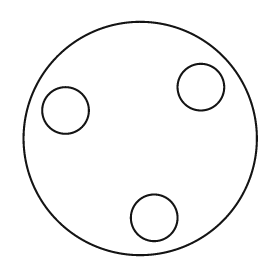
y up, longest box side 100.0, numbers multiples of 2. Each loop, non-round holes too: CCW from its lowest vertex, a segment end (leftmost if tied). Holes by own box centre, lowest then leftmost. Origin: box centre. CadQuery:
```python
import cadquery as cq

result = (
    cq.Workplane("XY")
    .moveTo(0.0, 0.0)
    .circle(50.0)
    .moveTo(6.0, -34.0)
    .circle(10.0)
    .moveTo(-32.0, 12.0)
    .circle(10.0)
    .moveTo(26.0, 22.0)
    .circle(10.0)
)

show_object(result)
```